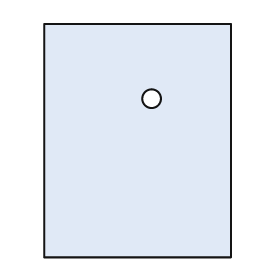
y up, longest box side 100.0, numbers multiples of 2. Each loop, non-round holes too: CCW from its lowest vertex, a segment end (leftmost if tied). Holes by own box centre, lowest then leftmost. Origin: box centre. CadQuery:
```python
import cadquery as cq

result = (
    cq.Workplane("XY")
    .moveTo(-40.0, -50.0)
    .lineTo(40.0, -50.0)
    .lineTo(40.0, 50.0)
    .lineTo(-40.0, 50.0)
    .close()
    .moveTo(6.0, 18.0)
    .circle(4.0)
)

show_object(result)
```